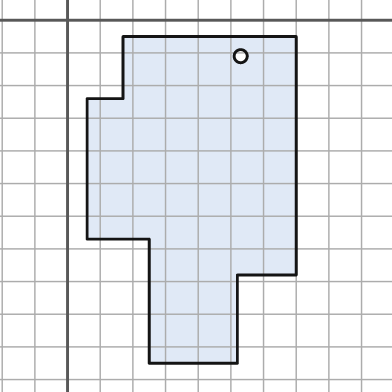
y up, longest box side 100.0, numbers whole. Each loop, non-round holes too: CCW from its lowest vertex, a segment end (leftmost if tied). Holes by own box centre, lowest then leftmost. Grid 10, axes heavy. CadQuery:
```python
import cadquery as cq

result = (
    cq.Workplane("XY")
    .moveTo(25.0, -105.0)
    .lineTo(52.0, -105.0)
    .lineTo(52.0, -78.0)
    .lineTo(70.0, -78.0)
    .lineTo(70.0, -5.0)
    .lineTo(17.0, -5.0)
    .lineTo(17.0, -24.0)
    .lineTo(6.0, -24.0)
    .lineTo(6.0, -67.0)
    .lineTo(25.0, -67.0)
    .close()
    .moveTo(53.0, -11.0)
    .circle(2.0)
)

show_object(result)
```